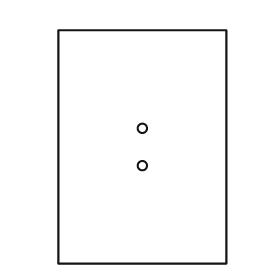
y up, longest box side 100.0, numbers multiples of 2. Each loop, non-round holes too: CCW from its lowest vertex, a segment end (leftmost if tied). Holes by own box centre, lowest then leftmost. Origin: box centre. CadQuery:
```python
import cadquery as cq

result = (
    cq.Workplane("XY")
    .moveTo(-36.0, -50.0)
    .lineTo(36.0, -50.0)
    .lineTo(36.0, 50.0)
    .lineTo(-36.0, 50.0)
    .close()
    .moveTo(0.0, -8.0)
    .circle(2.0)
    .moveTo(0.0, 8.0)
    .circle(2.0)
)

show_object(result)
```